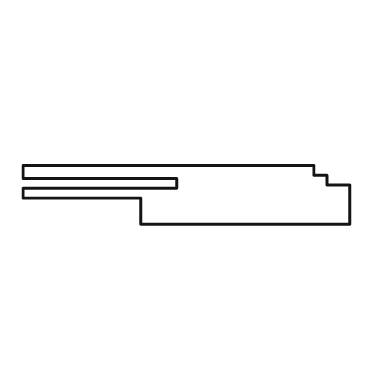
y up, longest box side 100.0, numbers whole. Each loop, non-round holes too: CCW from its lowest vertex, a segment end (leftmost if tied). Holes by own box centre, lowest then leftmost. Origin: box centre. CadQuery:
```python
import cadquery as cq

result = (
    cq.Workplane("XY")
    .moveTo(-14.0, -9.0)
    .lineTo(50.0, -9.0)
    .lineTo(50.0, 3.0)
    .lineTo(43.0, 3.0)
    .lineTo(43.0, 6.0)
    .lineTo(39.0, 6.0)
    .lineTo(39.0, 9.0)
    .lineTo(-50.0, 9.0)
    .lineTo(-50.0, 5.0)
    .lineTo(-3.0, 5.0)
    .lineTo(-3.0, 2.0)
    .lineTo(-50.0, 2.0)
    .lineTo(-50.0, -1.0)
    .lineTo(-14.0, -1.0)
    .close()
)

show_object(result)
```